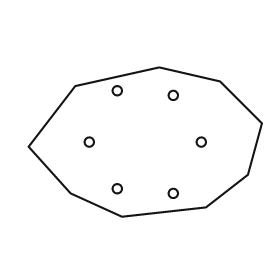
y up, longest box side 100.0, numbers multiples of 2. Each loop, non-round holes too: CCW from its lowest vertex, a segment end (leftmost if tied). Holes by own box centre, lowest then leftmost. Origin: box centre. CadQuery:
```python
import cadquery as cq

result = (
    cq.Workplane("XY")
    .moveTo(-10.0, -32.0)
    .lineTo(26.0, -28.0)
    .lineTo(44.0, -14.0)
    .lineTo(50.0, 8.0)
    .lineTo(32.0, 26.0)
    .lineTo(6.0, 32.0)
    .lineTo(-30.0, 24.0)
    .lineTo(-50.0, -2.0)
    .lineTo(-32.0, -22.0)
    .close()
    .moveTo(12.0, -22.0)
    .circle(2.0)
    .moveTo(-12.0, -20.0)
    .circle(2.0)
    .moveTo(-24.0, 0.0)
    .circle(2.0)
    .moveTo(24.0, 0.0)
    .circle(2.0)
    .moveTo(12.0, 20.0)
    .circle(2.0)
    .moveTo(-12.0, 22.0)
    .circle(2.0)
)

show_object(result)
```